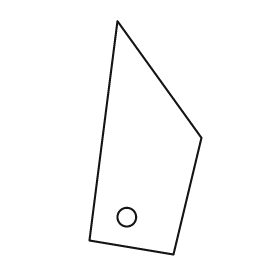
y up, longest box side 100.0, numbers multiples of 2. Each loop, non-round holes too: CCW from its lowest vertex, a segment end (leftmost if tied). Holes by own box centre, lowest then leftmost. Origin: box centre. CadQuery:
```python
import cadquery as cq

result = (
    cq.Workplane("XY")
    .moveTo(12.0, -50.0)
    .lineTo(24.0, 0.0)
    .lineTo(-12.0, 50.0)
    .lineTo(-24.0, -44.0)
    .close()
    .moveTo(-8.0, -34.0)
    .circle(4.0)
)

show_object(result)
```